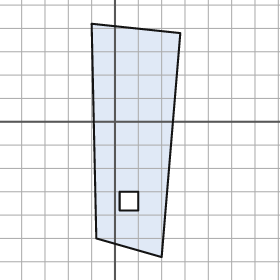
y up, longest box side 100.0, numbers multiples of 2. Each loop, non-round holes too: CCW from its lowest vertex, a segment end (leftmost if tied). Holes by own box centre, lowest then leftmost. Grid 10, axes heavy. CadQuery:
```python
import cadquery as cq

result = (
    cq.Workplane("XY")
    .moveTo(20.0, -58.0)
    .lineTo(28.0, 38.0)
    .lineTo(-10.0, 42.0)
    .lineTo(-8.0, -50.0)
    .close()
    .moveTo(2.0, -38.0)
    .lineTo(10.0, -38.0)
    .lineTo(10.0, -30.0)
    .lineTo(2.0, -30.0)
    .close()
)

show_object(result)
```